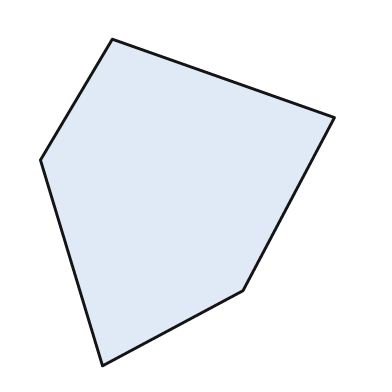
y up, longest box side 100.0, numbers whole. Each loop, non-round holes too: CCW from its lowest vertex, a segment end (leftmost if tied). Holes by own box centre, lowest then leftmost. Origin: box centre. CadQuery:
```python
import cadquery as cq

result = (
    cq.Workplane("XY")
    .moveTo(-26.0, -50.0)
    .lineTo(17.0, -27.0)
    .lineTo(45.0, 26.0)
    .lineTo(-23.0, 50.0)
    .lineTo(-45.0, 13.0)
    .close()
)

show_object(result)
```